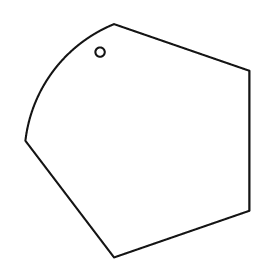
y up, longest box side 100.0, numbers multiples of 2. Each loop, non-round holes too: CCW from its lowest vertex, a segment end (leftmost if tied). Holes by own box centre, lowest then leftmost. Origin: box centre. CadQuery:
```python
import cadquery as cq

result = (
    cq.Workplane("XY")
    .moveTo(-10.0, -50.0)
    .lineTo(48.0, -30.0)
    .lineTo(48.0, 30.0)
    .lineTo(-10.0, 50.0)
    .threePointArc((-36.0, 30.0), (-48.0, 0.0))
    .close()
    .moveTo(-16.0, 38.0)
    .circle(2.0)
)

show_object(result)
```